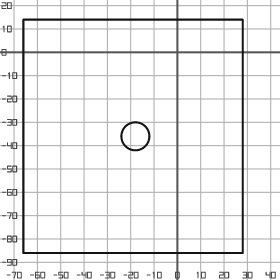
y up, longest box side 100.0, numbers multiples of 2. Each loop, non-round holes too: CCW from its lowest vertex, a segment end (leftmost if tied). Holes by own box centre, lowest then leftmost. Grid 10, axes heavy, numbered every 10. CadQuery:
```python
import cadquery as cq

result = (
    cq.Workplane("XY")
    .moveTo(-66.0, -86.0)
    .lineTo(28.0, -86.0)
    .lineTo(28.0, 14.0)
    .lineTo(-66.0, 14.0)
    .close()
    .moveTo(-18.0, -36.0)
    .circle(6.0)
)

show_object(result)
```